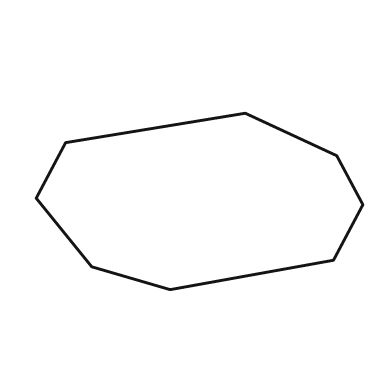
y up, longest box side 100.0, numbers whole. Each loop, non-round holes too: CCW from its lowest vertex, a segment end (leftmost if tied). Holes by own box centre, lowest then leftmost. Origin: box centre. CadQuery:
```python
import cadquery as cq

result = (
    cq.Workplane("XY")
    .moveTo(-9.0, -27.0)
    .lineTo(41.0, -18.0)
    .lineTo(50.0, -1.0)
    .lineTo(42.0, 14.0)
    .lineTo(14.0, 27.0)
    .lineTo(-41.0, 18.0)
    .lineTo(-50.0, 1.0)
    .lineTo(-33.0, -20.0)
    .close()
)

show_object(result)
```